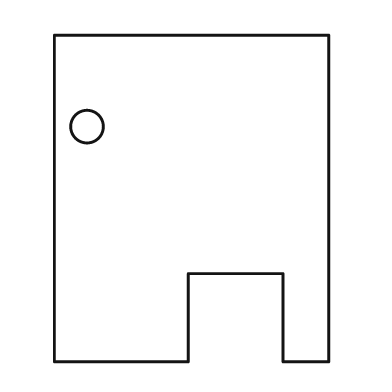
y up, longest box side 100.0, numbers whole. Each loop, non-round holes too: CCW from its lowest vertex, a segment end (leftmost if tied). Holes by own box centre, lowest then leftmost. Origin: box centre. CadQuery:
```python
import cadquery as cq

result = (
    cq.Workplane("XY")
    .moveTo(-42.0, -50.0)
    .lineTo(-1.0, -50.0)
    .lineTo(-1.0, -23.0)
    .lineTo(28.0, -23.0)
    .lineTo(28.0, -50.0)
    .lineTo(42.0, -50.0)
    .lineTo(42.0, 50.0)
    .lineTo(-42.0, 50.0)
    .close()
    .moveTo(-32.0, 22.0)
    .circle(5.0)
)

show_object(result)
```